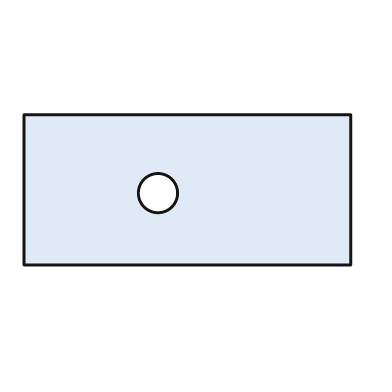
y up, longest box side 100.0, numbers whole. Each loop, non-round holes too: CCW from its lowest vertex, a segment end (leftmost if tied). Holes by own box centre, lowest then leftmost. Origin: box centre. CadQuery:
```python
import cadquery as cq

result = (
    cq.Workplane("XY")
    .moveTo(-50.0, -23.0)
    .lineTo(50.0, -23.0)
    .lineTo(50.0, 23.0)
    .lineTo(-50.0, 23.0)
    .close()
    .moveTo(-9.0, -1.0)
    .circle(6.0)
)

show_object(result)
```